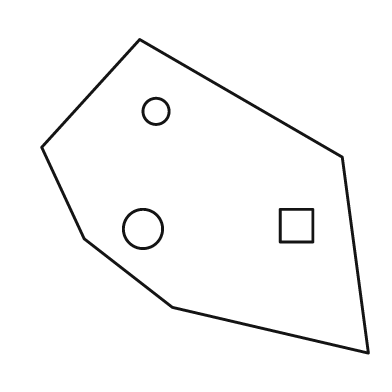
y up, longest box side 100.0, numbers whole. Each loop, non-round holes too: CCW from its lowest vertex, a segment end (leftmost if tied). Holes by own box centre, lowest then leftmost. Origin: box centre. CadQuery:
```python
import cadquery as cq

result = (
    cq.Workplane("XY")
    .moveTo(50.0, -48.0)
    .lineTo(42.0, 12.0)
    .lineTo(-20.0, 48.0)
    .lineTo(-50.0, 15.0)
    .lineTo(-37.0, -13.0)
    .lineTo(-10.0, -34.0)
    .close()
    .moveTo(-19.0, -10.0)
    .circle(6.0)
    .moveTo(23.0, -14.0)
    .lineTo(33.0, -14.0)
    .lineTo(33.0, -4.0)
    .lineTo(23.0, -4.0)
    .close()
    .moveTo(-15.0, 26.0)
    .circle(4.0)
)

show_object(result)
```